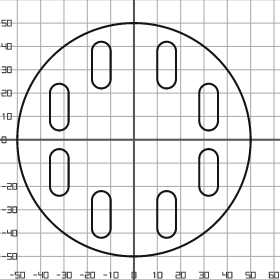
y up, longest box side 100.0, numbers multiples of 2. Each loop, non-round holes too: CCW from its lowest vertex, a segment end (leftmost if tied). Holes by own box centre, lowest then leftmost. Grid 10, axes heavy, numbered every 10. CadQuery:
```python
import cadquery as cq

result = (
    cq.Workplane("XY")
    .moveTo(0.0, 0.0)
    .circle(50.0)
    .moveTo(-18.0, -38.0)
    .threePointArc((-14.0, -42.0), (-10.0, -38.0))
    .lineTo(-10.0, -26.0)
    .threePointArc((-14.0, -22.0), (-18.0, -26.0))
    .close()
    .moveTo(10.0, -38.0)
    .threePointArc((14.0, -42.0), (18.0, -38.0))
    .lineTo(18.0, -26.0)
    .threePointArc((14.0, -22.0), (10.0, -26.0))
    .close()
    .moveTo(-36.0, -20.0)
    .threePointArc((-32.0, -24.0), (-28.0, -20.0))
    .lineTo(-28.0, -8.0)
    .threePointArc((-32.0, -4.0), (-36.0, -8.0))
    .close()
    .moveTo(28.0, -20.0)
    .threePointArc((32.0, -24.0), (36.0, -20.0))
    .lineTo(36.0, -8.0)
    .threePointArc((32.0, -4.0), (28.0, -8.0))
    .close()
    .moveTo(-36.0, 8.0)
    .threePointArc((-32.0, 4.0), (-28.0, 8.0))
    .lineTo(-28.0, 20.0)
    .threePointArc((-32.0, 24.0), (-36.0, 20.0))
    .close()
    .moveTo(28.0, 8.0)
    .threePointArc((32.0, 4.0), (36.0, 8.0))
    .lineTo(36.0, 20.0)
    .threePointArc((32.0, 24.0), (28.0, 20.0))
    .close()
    .moveTo(-18.0, 26.0)
    .threePointArc((-14.0, 22.0), (-10.0, 26.0))
    .lineTo(-10.0, 38.0)
    .threePointArc((-14.0, 42.0), (-18.0, 38.0))
    .close()
    .moveTo(10.0, 26.0)
    .threePointArc((14.0, 22.0), (18.0, 26.0))
    .lineTo(18.0, 38.0)
    .threePointArc((14.0, 42.0), (10.0, 38.0))
    .close()
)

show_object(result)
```